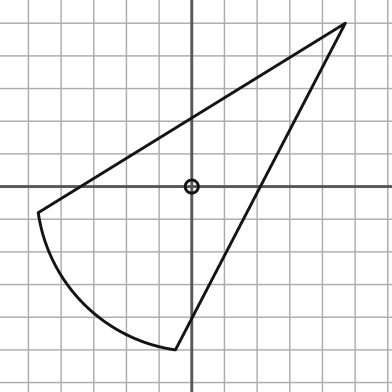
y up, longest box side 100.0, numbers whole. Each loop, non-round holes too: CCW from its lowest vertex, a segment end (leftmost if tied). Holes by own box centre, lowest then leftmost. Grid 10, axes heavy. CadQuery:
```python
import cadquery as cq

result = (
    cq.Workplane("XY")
    .moveTo(-5.0, -50.0)
    .lineTo(47.0, 50.0)
    .lineTo(-47.0, -8.0)
    .threePointArc((-33.0, -36.0), (-5.0, -50.0))
    .close()
    .moveTo(0.0, 0.0)
    .circle(2.0)
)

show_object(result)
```